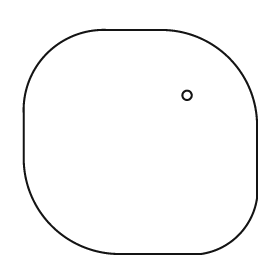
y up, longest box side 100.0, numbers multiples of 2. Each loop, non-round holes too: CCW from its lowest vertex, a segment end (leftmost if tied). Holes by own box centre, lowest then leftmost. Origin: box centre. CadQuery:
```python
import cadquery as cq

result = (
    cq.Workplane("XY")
    .moveTo(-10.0, -48.0)
    .lineTo(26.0, -48.0)
    .threePointArc((42.0, -40.0), (50.0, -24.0))
    .lineTo(50.0, 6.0)
    .threePointArc((38.0, 36.0), (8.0, 48.0))
    .lineTo(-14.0, 48.0)
    .threePointArc((-40.0, 38.0), (-50.0, 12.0))
    .lineTo(-50.0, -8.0)
    .threePointArc((-38.0, -36.0), (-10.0, -48.0))
    .close()
    .moveTo(20.0, 20.0)
    .circle(2.0)
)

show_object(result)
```